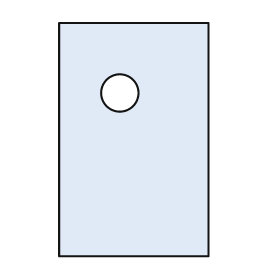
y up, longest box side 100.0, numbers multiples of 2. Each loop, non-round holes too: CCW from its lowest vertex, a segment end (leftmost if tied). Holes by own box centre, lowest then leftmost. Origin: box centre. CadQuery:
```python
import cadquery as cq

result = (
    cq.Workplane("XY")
    .moveTo(-32.0, -50.0)
    .lineTo(32.0, -50.0)
    .lineTo(32.0, 50.0)
    .lineTo(-32.0, 50.0)
    .close()
    .moveTo(-6.0, 20.0)
    .circle(8.0)
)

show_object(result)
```